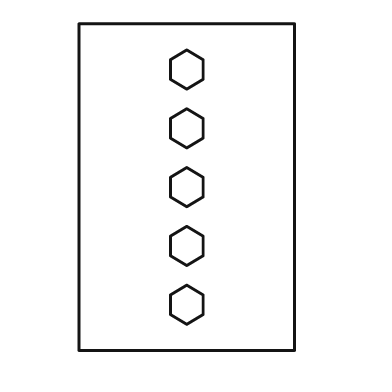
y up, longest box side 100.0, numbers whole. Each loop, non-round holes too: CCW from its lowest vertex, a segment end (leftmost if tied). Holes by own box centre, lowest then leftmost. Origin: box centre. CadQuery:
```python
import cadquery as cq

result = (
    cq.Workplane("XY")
    .moveTo(-33.0, -50.0)
    .lineTo(33.0, -50.0)
    .lineTo(33.0, 50.0)
    .lineTo(-33.0, 50.0)
    .close()
    .moveTo(0.0, -42.0)
    .lineTo(5.0, -39.0)
    .lineTo(5.0, -33.0)
    .lineTo(0.0, -30.0)
    .lineTo(-5.0, -33.0)
    .lineTo(-5.0, -39.0)
    .close()
    .moveTo(0.0, -24.0)
    .lineTo(5.0, -21.0)
    .lineTo(5.0, -15.0)
    .lineTo(0.0, -12.0)
    .lineTo(-5.0, -15.0)
    .lineTo(-5.0, -21.0)
    .close()
    .moveTo(0.0, -6.0)
    .lineTo(5.0, -3.0)
    .lineTo(5.0, 3.0)
    .lineTo(0.0, 6.0)
    .lineTo(-5.0, 3.0)
    .lineTo(-5.0, -3.0)
    .close()
    .moveTo(0.0, 12.0)
    .lineTo(5.0, 15.0)
    .lineTo(5.0, 21.0)
    .lineTo(0.0, 24.0)
    .lineTo(-5.0, 21.0)
    .lineTo(-5.0, 15.0)
    .close()
    .moveTo(0.0, 30.0)
    .lineTo(5.0, 33.0)
    .lineTo(5.0, 39.0)
    .lineTo(0.0, 42.0)
    .lineTo(-5.0, 39.0)
    .lineTo(-5.0, 33.0)
    .close()
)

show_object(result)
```